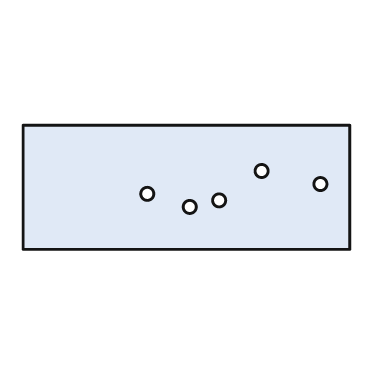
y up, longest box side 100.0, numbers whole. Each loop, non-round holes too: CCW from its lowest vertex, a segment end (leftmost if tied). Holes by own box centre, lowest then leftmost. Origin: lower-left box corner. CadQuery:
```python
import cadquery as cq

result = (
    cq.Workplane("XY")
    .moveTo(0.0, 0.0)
    .lineTo(100.0, 0.0)
    .lineTo(100.0, 38.0)
    .lineTo(0.0, 38.0)
    .close()
    .moveTo(51.0, 13.0)
    .circle(2.0)
    .moveTo(60.0, 15.0)
    .circle(2.0)
    .moveTo(38.0, 17.0)
    .circle(2.0)
    .moveTo(91.0, 20.0)
    .circle(2.0)
    .moveTo(73.0, 24.0)
    .circle(2.0)
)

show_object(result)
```